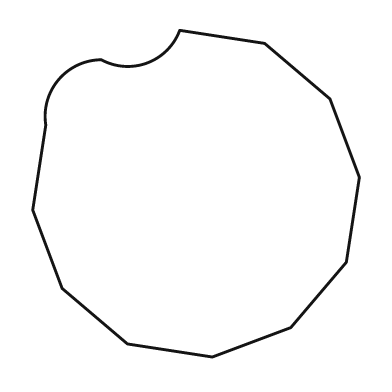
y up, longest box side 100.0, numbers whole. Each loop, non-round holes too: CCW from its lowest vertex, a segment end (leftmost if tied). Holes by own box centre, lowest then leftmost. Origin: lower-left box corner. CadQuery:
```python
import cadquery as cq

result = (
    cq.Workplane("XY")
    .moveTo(55.0, 0.0)
    .lineTo(79.0, 9.0)
    .lineTo(96.0, 29.0)
    .lineTo(100.0, 55.0)
    .lineTo(91.0, 79.0)
    .lineTo(71.0, 96.0)
    .lineTo(45.0, 100.0)
    .threePointArc((35.0, 90.0), (21.0, 91.0))
    .threePointArc((8.0, 85.0), (4.0, 71.0))
    .lineTo(0.0, 45.0)
    .lineTo(9.0, 21.0)
    .lineTo(29.0, 4.0)
    .close()
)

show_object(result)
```